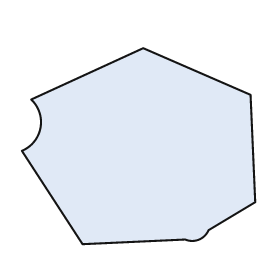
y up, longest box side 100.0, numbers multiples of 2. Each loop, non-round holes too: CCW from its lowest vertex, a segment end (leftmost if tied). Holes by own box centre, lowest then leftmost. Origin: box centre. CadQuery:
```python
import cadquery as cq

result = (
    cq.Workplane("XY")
    .moveTo(-24.0, -42.0)
    .lineTo(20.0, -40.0)
    .threePointArc((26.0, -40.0), (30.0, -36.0))
    .lineTo(50.0, -24.0)
    .lineTo(48.0, 22.0)
    .lineTo(2.0, 42.0)
    .lineTo(-46.0, 20.0)
    .threePointArc((-42.0, 8.0), (-50.0, -2.0))
    .close()
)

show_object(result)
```